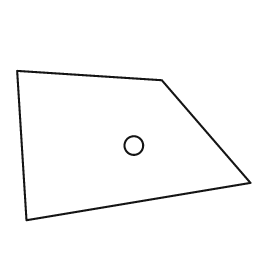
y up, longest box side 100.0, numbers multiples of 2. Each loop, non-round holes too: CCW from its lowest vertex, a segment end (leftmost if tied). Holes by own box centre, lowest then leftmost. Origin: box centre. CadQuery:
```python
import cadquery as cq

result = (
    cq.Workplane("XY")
    .moveTo(-46.0, -32.0)
    .lineTo(50.0, -16.0)
    .lineTo(12.0, 28.0)
    .lineTo(-50.0, 32.0)
    .close()
    .moveTo(0.0, 0.0)
    .circle(4.0)
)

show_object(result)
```